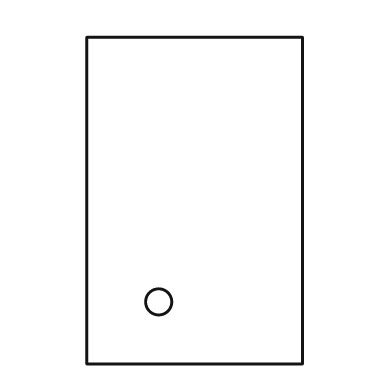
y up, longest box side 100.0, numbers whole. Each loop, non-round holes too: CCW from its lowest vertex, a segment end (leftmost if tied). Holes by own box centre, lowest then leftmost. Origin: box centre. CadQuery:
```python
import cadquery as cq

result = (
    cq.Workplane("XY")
    .moveTo(-33.0, -50.0)
    .lineTo(33.0, -50.0)
    .lineTo(33.0, 50.0)
    .lineTo(-33.0, 50.0)
    .close()
    .moveTo(-11.0, -31.0)
    .circle(4.0)
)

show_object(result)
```